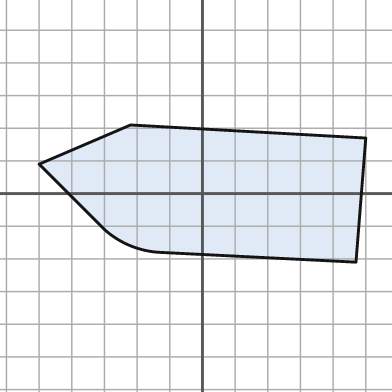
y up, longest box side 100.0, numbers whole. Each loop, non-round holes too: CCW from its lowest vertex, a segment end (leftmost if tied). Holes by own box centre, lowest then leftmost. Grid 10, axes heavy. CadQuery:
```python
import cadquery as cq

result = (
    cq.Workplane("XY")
    .moveTo(47.0, -21.0)
    .lineTo(50.0, 17.0)
    .lineTo(-22.0, 21.0)
    .lineTo(-50.0, 9.0)
    .lineTo(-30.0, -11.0)
    .threePointArc((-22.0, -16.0), (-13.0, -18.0))
    .close()
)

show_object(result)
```